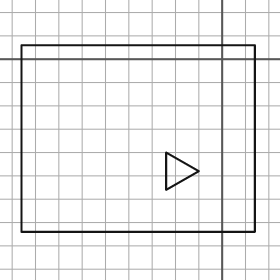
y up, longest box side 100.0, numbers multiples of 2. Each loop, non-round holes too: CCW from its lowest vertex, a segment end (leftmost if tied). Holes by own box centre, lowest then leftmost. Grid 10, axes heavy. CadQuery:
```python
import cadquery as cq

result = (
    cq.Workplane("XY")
    .moveTo(-86.0, -74.0)
    .lineTo(14.0, -74.0)
    .lineTo(14.0, 6.0)
    .lineTo(-86.0, 6.0)
    .close()
    .moveTo(-24.0, -56.0)
    .lineTo(-10.0, -48.0)
    .lineTo(-24.0, -40.0)
    .close()
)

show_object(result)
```